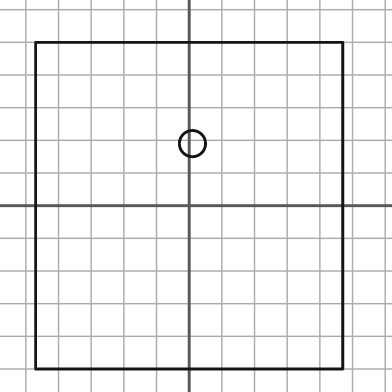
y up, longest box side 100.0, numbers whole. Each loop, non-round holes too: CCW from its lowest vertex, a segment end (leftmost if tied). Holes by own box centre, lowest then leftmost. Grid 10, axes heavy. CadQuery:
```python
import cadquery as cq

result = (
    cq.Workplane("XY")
    .moveTo(-47.0, -50.0)
    .lineTo(47.0, -50.0)
    .lineTo(47.0, 50.0)
    .lineTo(-47.0, 50.0)
    .close()
    .moveTo(1.0, 19.0)
    .circle(4.0)
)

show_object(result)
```